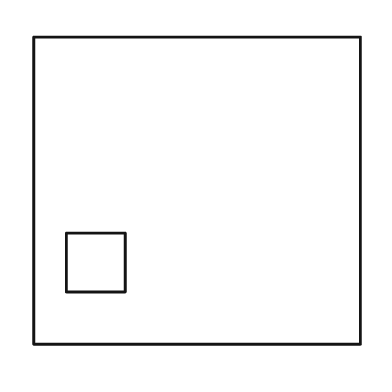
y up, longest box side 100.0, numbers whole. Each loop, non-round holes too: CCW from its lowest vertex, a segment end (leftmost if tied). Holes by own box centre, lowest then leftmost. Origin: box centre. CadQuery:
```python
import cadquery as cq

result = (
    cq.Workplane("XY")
    .moveTo(-50.0, -47.0)
    .lineTo(50.0, -47.0)
    .lineTo(50.0, 47.0)
    .lineTo(-50.0, 47.0)
    .close()
    .moveTo(-40.0, -31.0)
    .lineTo(-22.0, -31.0)
    .lineTo(-22.0, -13.0)
    .lineTo(-40.0, -13.0)
    .close()
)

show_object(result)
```